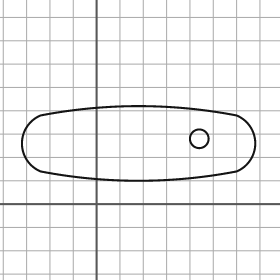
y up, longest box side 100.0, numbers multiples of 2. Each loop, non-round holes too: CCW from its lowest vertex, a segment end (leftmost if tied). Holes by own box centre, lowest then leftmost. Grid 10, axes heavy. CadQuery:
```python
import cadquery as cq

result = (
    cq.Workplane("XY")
    .moveTo(-24.0, 14.0)
    .threePointArc((18.0, 10.0), (60.0, 14.0))
    .threePointArc((68.0, 26.0), (60.0, 38.0))
    .threePointArc((18.0, 42.0), (-24.0, 38.0))
    .threePointArc((-32.0, 26.0), (-24.0, 14.0))
    .close()
    .moveTo(44.0, 28.0)
    .circle(4.0)
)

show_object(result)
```